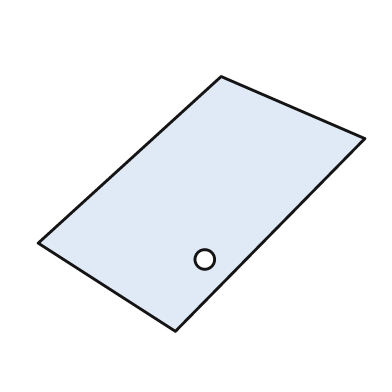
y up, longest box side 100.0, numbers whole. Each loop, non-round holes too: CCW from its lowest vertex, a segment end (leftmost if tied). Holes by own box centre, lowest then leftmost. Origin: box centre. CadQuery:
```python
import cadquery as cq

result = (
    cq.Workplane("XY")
    .moveTo(-8.0, -39.0)
    .lineTo(50.0, 20.0)
    .lineTo(6.0, 39.0)
    .lineTo(-50.0, -12.0)
    .close()
    .moveTo(1.0, -17.0)
    .circle(3.0)
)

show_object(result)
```